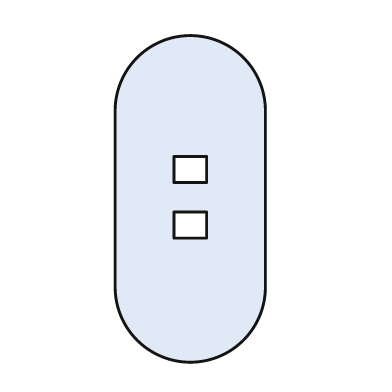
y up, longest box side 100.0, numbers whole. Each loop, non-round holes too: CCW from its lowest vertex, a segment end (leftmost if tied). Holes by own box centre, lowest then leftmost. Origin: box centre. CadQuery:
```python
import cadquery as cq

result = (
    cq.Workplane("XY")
    .moveTo(-23.0, -27.0)
    .threePointArc((0.0, -50.0), (23.0, -27.0))
    .lineTo(23.0, 27.0)
    .threePointArc((0.0, 50.0), (-23.0, 27.0))
    .close()
    .moveTo(-5.0, -12.0)
    .lineTo(5.0, -12.0)
    .lineTo(5.0, -4.0)
    .lineTo(-5.0, -4.0)
    .close()
    .moveTo(-5.0, 5.0)
    .lineTo(5.0, 5.0)
    .lineTo(5.0, 13.0)
    .lineTo(-5.0, 13.0)
    .close()
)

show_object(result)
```